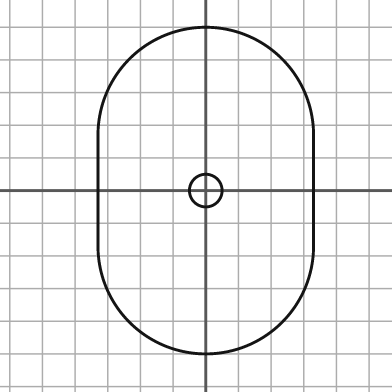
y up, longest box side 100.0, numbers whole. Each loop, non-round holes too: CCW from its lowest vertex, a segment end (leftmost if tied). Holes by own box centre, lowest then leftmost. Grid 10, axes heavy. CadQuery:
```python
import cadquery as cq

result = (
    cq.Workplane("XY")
    .moveTo(-33.0, -17.0)
    .threePointArc((0.0, -50.0), (33.0, -17.0))
    .lineTo(33.0, 17.0)
    .threePointArc((0.0, 50.0), (-33.0, 17.0))
    .close()
    .moveTo(0.0, 0.0)
    .circle(5.0)
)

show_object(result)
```